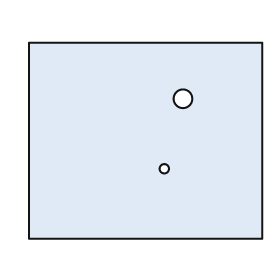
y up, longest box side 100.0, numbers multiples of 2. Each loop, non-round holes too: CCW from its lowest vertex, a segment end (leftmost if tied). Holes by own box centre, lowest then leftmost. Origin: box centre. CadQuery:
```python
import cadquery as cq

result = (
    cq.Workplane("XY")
    .moveTo(-50.0, -42.0)
    .lineTo(50.0, -42.0)
    .lineTo(50.0, 42.0)
    .lineTo(-50.0, 42.0)
    .close()
    .moveTo(8.0, -12.0)
    .circle(2.0)
    .moveTo(16.0, 18.0)
    .circle(4.0)
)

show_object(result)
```